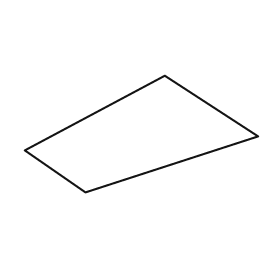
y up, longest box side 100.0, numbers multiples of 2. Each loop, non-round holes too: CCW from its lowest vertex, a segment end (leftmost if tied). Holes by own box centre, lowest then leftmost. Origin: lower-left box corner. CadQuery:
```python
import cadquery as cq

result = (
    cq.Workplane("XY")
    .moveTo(26.0, 0.0)
    .lineTo(100.0, 24.0)
    .lineTo(60.0, 50.0)
    .lineTo(0.0, 18.0)
    .close()
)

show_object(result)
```